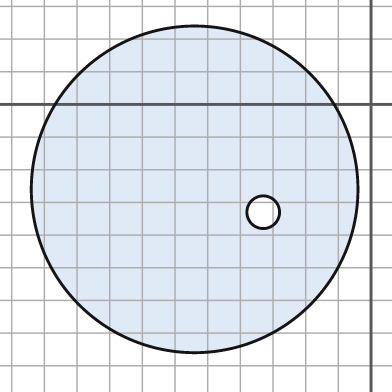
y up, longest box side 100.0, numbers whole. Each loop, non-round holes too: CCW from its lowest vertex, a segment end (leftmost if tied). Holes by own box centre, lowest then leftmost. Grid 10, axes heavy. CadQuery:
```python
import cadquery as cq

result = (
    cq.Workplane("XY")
    .moveTo(-54.0, -26.0)
    .circle(50.0)
    .moveTo(-33.0, -33.0)
    .circle(5.0)
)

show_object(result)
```